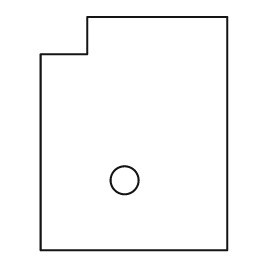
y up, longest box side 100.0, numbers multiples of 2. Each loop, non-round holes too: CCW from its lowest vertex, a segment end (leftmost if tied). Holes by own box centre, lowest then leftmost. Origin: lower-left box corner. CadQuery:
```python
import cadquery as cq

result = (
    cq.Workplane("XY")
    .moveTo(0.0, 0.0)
    .lineTo(80.0, 0.0)
    .lineTo(80.0, 100.0)
    .lineTo(20.0, 100.0)
    .lineTo(20.0, 84.0)
    .lineTo(0.0, 84.0)
    .close()
    .moveTo(36.0, 30.0)
    .circle(6.0)
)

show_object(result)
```